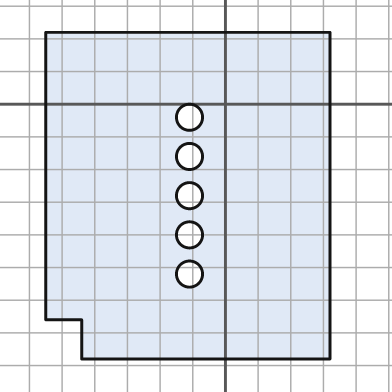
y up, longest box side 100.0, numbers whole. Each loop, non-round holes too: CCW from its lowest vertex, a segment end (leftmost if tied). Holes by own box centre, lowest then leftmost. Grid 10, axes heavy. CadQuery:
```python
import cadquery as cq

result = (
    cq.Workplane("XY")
    .moveTo(-44.0, -78.0)
    .lineTo(32.0, -78.0)
    .lineTo(32.0, 22.0)
    .lineTo(-55.0, 22.0)
    .lineTo(-55.0, -66.0)
    .lineTo(-44.0, -66.0)
    .close()
    .moveTo(-11.0, -52.0)
    .circle(4.0)
    .moveTo(-11.0, -40.0)
    .circle(4.0)
    .moveTo(-11.0, -28.0)
    .circle(4.0)
    .moveTo(-11.0, -16.0)
    .circle(4.0)
    .moveTo(-11.0, -4.0)
    .circle(4.0)
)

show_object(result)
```